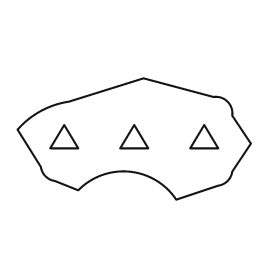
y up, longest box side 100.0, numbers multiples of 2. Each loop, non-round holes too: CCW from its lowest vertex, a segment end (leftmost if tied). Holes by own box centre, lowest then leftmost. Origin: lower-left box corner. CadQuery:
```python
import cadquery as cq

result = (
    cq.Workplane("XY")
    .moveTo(68.0, 0.0)
    .lineTo(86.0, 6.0)
    .threePointArc((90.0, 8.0), (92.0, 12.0))
    .lineTo(100.0, 24.0)
    .lineTo(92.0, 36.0)
    .threePointArc((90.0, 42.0), (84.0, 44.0))
    .lineTo(54.0, 52.0)
    .lineTo(22.0, 42.0)
    .threePointArc((10.0, 38.0), (0.0, 30.0))
    .lineTo(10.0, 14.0)
    .threePointArc((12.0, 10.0), (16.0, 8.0))
    .lineTo(26.0, 4.0)
    .threePointArc((48.0, 12.0), (68.0, 0.0))
    .close()
    .moveTo(14.0, 22.0)
    .lineTo(26.0, 22.0)
    .lineTo(20.0, 32.0)
    .close()
    .moveTo(44.0, 22.0)
    .lineTo(56.0, 22.0)
    .lineTo(50.0, 32.0)
    .close()
    .moveTo(74.0, 22.0)
    .lineTo(86.0, 22.0)
    .lineTo(80.0, 32.0)
    .close()
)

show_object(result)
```